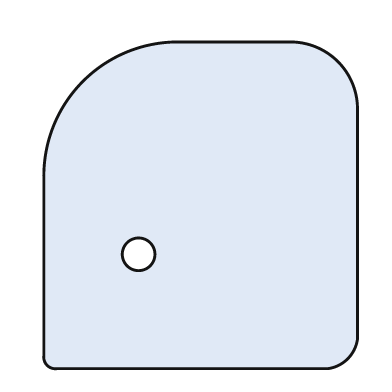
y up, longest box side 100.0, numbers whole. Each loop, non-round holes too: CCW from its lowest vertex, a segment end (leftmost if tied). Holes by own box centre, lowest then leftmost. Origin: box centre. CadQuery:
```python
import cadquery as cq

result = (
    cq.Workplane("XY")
    .moveTo(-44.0, -50.0)
    .lineTo(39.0, -50.0)
    .threePointArc((45.0, -47.0), (48.0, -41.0))
    .lineTo(48.0, 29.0)
    .threePointArc((42.0, 44.0), (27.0, 50.0))
    .lineTo(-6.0, 50.0)
    .threePointArc((-36.0, 38.0), (-48.0, 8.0))
    .lineTo(-48.0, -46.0)
    .threePointArc((-47.0, -49.0), (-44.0, -50.0))
    .close()
    .moveTo(-19.0, -15.0)
    .circle(5.0)
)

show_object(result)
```